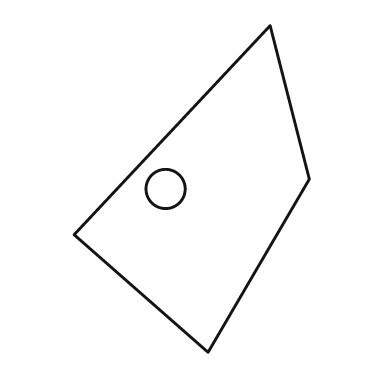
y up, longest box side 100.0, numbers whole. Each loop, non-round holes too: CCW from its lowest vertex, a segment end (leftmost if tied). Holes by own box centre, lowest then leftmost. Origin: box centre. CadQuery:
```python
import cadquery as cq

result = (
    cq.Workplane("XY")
    .moveTo(5.0, -50.0)
    .lineTo(36.0, 3.0)
    .lineTo(24.0, 50.0)
    .lineTo(-36.0, -14.0)
    .close()
    .moveTo(-8.0, 0.0)
    .circle(6.0)
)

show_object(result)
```